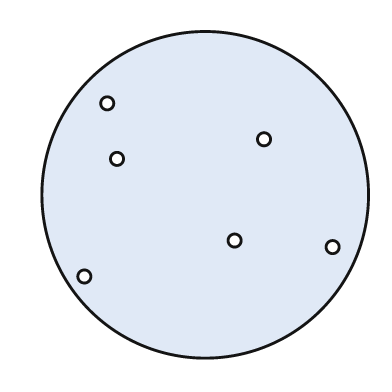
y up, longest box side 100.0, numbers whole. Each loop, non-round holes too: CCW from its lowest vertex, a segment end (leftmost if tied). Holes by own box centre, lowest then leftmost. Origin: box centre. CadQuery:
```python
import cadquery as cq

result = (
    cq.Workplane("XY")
    .moveTo(0.0, 0.0)
    .circle(50.0)
    .moveTo(-37.0, -25.0)
    .circle(2.0)
    .moveTo(39.0, -16.0)
    .circle(2.0)
    .moveTo(9.0, -14.0)
    .circle(2.0)
    .moveTo(-27.0, 11.0)
    .circle(2.0)
    .moveTo(18.0, 17.0)
    .circle(2.0)
    .moveTo(-30.0, 28.0)
    .circle(2.0)
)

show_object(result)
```